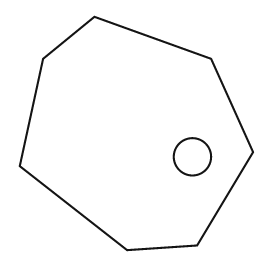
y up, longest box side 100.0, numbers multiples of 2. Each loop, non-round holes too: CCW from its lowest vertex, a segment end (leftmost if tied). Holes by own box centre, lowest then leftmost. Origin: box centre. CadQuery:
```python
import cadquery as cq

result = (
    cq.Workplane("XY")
    .moveTo(-4.0, -50.0)
    .lineTo(26.0, -48.0)
    .lineTo(50.0, -8.0)
    .lineTo(32.0, 32.0)
    .lineTo(-18.0, 50.0)
    .lineTo(-40.0, 32.0)
    .lineTo(-50.0, -14.0)
    .close()
    .moveTo(24.0, -10.0)
    .circle(8.0)
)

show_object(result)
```